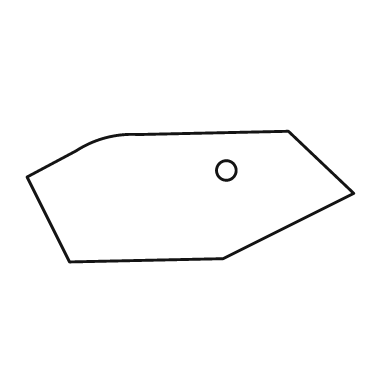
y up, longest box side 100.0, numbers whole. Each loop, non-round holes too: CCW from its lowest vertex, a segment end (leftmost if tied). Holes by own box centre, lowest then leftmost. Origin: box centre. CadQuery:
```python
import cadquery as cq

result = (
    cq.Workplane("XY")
    .moveTo(-37.0, -20.0)
    .lineTo(10.0, -19.0)
    .lineTo(50.0, 1.0)
    .lineTo(30.0, 20.0)
    .lineTo(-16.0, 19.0)
    .threePointArc((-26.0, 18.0), (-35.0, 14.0))
    .lineTo(-50.0, 6.0)
    .close()
    .moveTo(11.0, 8.0)
    .circle(3.0)
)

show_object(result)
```